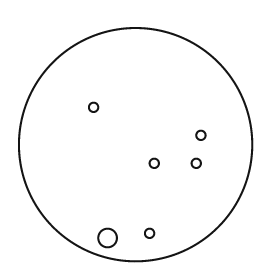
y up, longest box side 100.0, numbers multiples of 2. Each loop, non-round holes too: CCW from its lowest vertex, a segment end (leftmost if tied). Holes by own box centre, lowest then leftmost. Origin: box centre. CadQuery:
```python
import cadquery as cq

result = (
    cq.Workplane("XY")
    .moveTo(0.0, 0.0)
    .circle(50.0)
    .moveTo(-12.0, -40.0)
    .circle(4.0)
    .moveTo(6.0, -38.0)
    .circle(2.0)
    .moveTo(8.0, -8.0)
    .circle(2.0)
    .moveTo(26.0, -8.0)
    .circle(2.0)
    .moveTo(28.0, 4.0)
    .circle(2.0)
    .moveTo(-18.0, 16.0)
    .circle(2.0)
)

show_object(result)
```